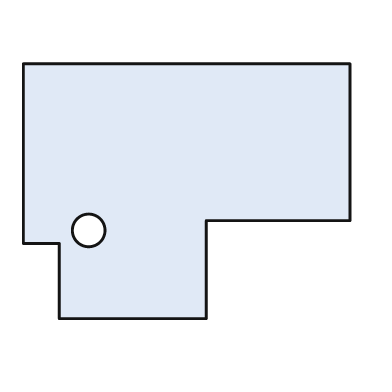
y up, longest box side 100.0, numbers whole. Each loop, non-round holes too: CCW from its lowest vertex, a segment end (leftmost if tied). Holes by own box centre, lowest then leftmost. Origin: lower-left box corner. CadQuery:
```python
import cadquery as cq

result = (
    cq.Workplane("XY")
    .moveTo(11.0, 0.0)
    .lineTo(56.0, 0.0)
    .lineTo(56.0, 30.0)
    .lineTo(100.0, 30.0)
    .lineTo(100.0, 78.0)
    .lineTo(0.0, 78.0)
    .lineTo(0.0, 23.0)
    .lineTo(11.0, 23.0)
    .close()
    .moveTo(20.0, 27.0)
    .circle(5.0)
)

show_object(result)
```